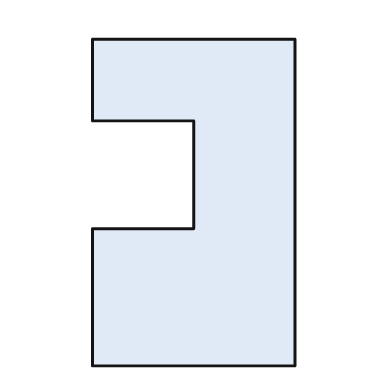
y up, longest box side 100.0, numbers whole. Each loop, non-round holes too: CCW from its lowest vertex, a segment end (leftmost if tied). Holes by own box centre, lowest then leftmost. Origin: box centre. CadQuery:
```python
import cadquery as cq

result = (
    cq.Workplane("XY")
    .moveTo(-31.0, -50.0)
    .lineTo(31.0, -50.0)
    .lineTo(31.0, 50.0)
    .lineTo(-31.0, 50.0)
    .lineTo(-31.0, 25.0)
    .lineTo(0.0, 25.0)
    .lineTo(0.0, -8.0)
    .lineTo(-31.0, -8.0)
    .close()
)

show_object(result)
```